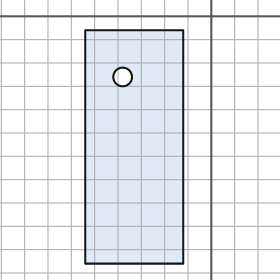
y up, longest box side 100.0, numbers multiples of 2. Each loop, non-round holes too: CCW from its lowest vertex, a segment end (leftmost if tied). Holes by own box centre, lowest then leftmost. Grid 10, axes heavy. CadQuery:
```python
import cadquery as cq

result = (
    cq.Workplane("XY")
    .moveTo(-54.0, -106.0)
    .lineTo(-12.0, -106.0)
    .lineTo(-12.0, -6.0)
    .lineTo(-54.0, -6.0)
    .close()
    .moveTo(-38.0, -26.0)
    .circle(4.0)
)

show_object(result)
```